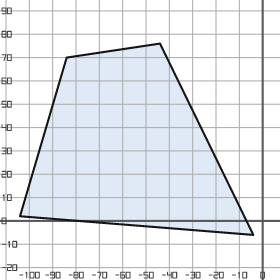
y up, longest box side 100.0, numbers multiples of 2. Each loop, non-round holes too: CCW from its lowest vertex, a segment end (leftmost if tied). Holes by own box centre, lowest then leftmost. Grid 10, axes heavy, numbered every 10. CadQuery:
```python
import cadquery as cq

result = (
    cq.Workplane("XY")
    .moveTo(-4.0, -6.0)
    .lineTo(-44.0, 76.0)
    .lineTo(-84.0, 70.0)
    .lineTo(-104.0, 2.0)
    .close()
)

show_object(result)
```